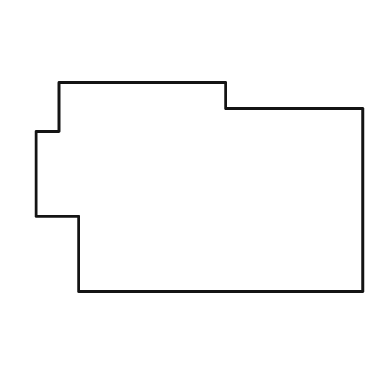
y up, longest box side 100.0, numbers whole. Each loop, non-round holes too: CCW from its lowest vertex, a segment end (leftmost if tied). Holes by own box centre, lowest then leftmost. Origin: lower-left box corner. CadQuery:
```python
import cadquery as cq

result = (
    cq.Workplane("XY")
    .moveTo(13.0, 0.0)
    .lineTo(100.0, 0.0)
    .lineTo(100.0, 56.0)
    .lineTo(58.0, 56.0)
    .lineTo(58.0, 64.0)
    .lineTo(7.0, 64.0)
    .lineTo(7.0, 49.0)
    .lineTo(0.0, 49.0)
    .lineTo(0.0, 23.0)
    .lineTo(13.0, 23.0)
    .close()
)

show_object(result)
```